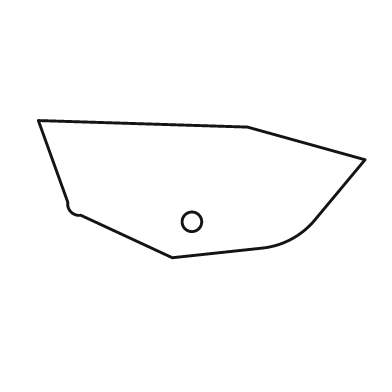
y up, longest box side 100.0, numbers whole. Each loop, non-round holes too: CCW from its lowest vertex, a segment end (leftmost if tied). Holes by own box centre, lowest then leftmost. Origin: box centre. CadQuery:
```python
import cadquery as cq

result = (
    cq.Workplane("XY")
    .moveTo(-9.0, -21.0)
    .lineTo(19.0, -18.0)
    .threePointArc((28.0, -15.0), (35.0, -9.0))
    .lineTo(50.0, 9.0)
    .lineTo(14.0, 19.0)
    .lineTo(-50.0, 21.0)
    .lineTo(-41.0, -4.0)
    .threePointArc((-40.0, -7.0), (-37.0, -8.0))
    .close()
    .moveTo(-3.0, -10.0)
    .circle(3.0)
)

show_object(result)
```